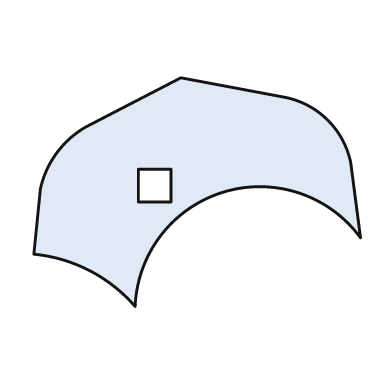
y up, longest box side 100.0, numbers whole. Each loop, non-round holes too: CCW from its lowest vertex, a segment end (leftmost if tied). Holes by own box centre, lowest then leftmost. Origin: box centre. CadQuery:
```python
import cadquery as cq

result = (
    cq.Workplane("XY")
    .moveTo(-19.0, -35.0)
    .threePointArc((8.0, 0.0), (50.0, -14.0))
    .lineTo(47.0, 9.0)
    .threePointArc((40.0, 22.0), (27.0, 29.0))
    .lineTo(-5.0, 35.0)
    .lineTo(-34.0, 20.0)
    .threePointArc((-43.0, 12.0), (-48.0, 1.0))
    .lineTo(-50.0, -19.0)
    .threePointArc((-33.0, -24.0), (-19.0, -35.0))
    .close()
    .moveTo(-18.0, -3.0)
    .lineTo(-8.0, -3.0)
    .lineTo(-8.0, 7.0)
    .lineTo(-18.0, 7.0)
    .close()
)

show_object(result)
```